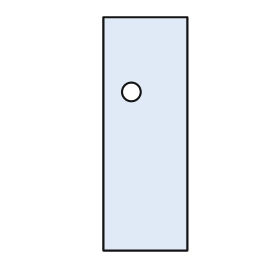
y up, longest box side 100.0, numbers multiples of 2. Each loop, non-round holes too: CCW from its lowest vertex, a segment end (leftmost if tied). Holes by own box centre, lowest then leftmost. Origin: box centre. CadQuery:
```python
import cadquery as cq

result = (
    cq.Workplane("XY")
    .moveTo(-18.0, -50.0)
    .lineTo(18.0, -50.0)
    .lineTo(18.0, 50.0)
    .lineTo(-18.0, 50.0)
    .close()
    .moveTo(-6.0, 18.0)
    .circle(4.0)
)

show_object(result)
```